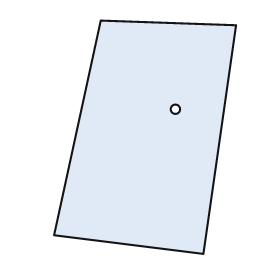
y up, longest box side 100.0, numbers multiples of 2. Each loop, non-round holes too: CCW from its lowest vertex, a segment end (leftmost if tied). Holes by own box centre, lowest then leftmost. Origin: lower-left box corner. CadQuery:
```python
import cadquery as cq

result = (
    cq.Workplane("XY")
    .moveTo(64.0, 0.0)
    .lineTo(78.0, 98.0)
    .lineTo(20.0, 100.0)
    .lineTo(0.0, 8.0)
    .close()
    .moveTo(52.0, 62.0)
    .circle(2.0)
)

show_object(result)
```